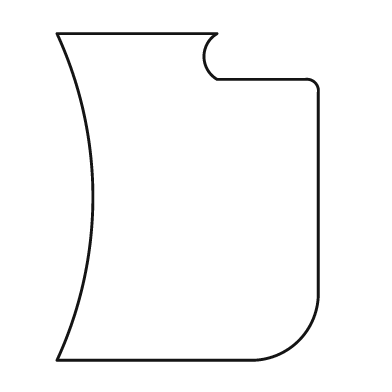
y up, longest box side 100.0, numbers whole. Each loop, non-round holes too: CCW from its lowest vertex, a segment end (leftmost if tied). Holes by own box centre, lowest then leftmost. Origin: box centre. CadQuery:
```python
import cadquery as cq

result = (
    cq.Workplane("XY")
    .moveTo(-40.0, -50.0)
    .lineTo(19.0, -50.0)
    .threePointArc((34.0, -44.0), (40.0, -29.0))
    .lineTo(40.0, 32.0)
    .threePointArc((39.0, 35.0), (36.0, 36.0))
    .lineTo(9.0, 36.0)
    .threePointArc((5.0, 43.0), (9.0, 50.0))
    .lineTo(-40.0, 50.0)
    .threePointArc((-29.0, 0.0), (-40.0, -50.0))
    .close()
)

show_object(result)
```